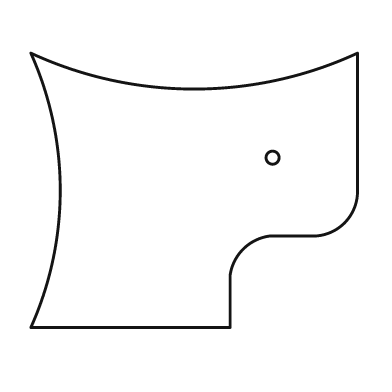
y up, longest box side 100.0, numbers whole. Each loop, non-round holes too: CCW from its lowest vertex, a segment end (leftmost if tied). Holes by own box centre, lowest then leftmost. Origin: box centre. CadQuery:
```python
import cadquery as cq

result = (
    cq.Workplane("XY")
    .moveTo(-50.0, -42.0)
    .lineTo(11.0, -42.0)
    .lineTo(11.0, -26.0)
    .threePointArc((15.0, -18.0), (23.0, -14.0))
    .lineTo(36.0, -14.0)
    .threePointArc((46.0, -10.0), (50.0, 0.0))
    .lineTo(50.0, 42.0)
    .threePointArc((0.0, 31.0), (-50.0, 42.0))
    .threePointArc((-41.0, 0.0), (-50.0, -42.0))
    .close()
    .moveTo(24.0, 10.0)
    .circle(2.0)
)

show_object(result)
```